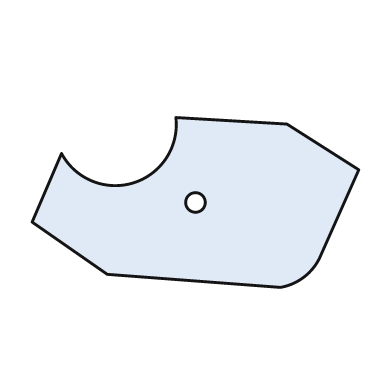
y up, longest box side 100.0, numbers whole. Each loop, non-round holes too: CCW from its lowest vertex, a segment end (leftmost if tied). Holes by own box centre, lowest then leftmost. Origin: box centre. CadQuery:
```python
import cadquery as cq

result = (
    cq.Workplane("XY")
    .moveTo(26.0, -26.0)
    .threePointArc((33.0, -23.0), (38.0, -17.0))
    .lineTo(50.0, 10.0)
    .lineTo(28.0, 24.0)
    .lineTo(-6.0, 26.0)
    .threePointArc((-19.0, 6.0), (-41.0, 15.0))
    .lineTo(-50.0, -6.0)
    .lineTo(-27.0, -22.0)
    .close()
    .moveTo(0.0, 0.0)
    .circle(3.0)
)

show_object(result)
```